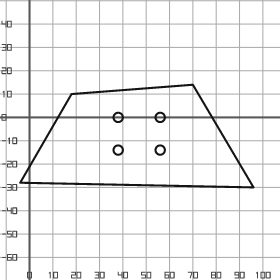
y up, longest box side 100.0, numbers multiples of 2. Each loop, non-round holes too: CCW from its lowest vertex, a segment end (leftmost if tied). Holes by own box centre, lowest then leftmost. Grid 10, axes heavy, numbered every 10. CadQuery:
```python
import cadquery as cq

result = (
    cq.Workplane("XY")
    .moveTo(96.0, -30.0)
    .lineTo(70.0, 14.0)
    .lineTo(18.0, 10.0)
    .lineTo(-4.0, -28.0)
    .close()
    .moveTo(38.0, -14.0)
    .circle(2.0)
    .moveTo(56.0, -14.0)
    .circle(2.0)
    .moveTo(38.0, 0.0)
    .circle(2.0)
    .moveTo(56.0, 0.0)
    .circle(2.0)
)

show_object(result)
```